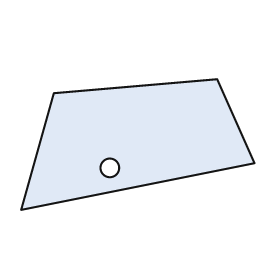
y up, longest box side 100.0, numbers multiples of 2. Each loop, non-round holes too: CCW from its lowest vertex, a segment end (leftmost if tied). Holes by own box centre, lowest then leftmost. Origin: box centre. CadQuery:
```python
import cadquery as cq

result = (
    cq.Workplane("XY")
    .moveTo(-50.0, -28.0)
    .lineTo(50.0, -8.0)
    .lineTo(34.0, 28.0)
    .lineTo(-36.0, 22.0)
    .close()
    .moveTo(-12.0, -10.0)
    .circle(4.0)
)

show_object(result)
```